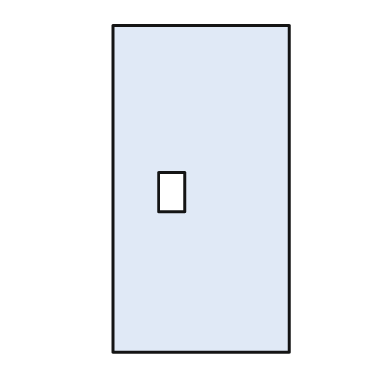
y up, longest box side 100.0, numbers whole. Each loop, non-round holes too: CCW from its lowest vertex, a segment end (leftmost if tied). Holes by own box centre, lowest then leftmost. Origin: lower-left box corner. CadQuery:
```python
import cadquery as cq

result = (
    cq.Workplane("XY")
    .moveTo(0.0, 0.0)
    .lineTo(54.0, 0.0)
    .lineTo(54.0, 100.0)
    .lineTo(0.0, 100.0)
    .close()
    .moveTo(14.0, 43.0)
    .lineTo(22.0, 43.0)
    .lineTo(22.0, 55.0)
    .lineTo(14.0, 55.0)
    .close()
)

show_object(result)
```